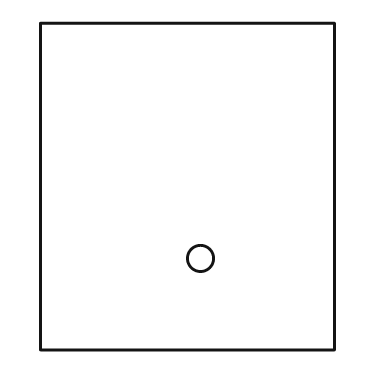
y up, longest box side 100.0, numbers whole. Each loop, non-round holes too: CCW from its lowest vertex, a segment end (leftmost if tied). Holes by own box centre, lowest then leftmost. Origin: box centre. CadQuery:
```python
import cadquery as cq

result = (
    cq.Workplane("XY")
    .moveTo(-45.0, -50.0)
    .lineTo(45.0, -50.0)
    .lineTo(45.0, 50.0)
    .lineTo(-45.0, 50.0)
    .close()
    .moveTo(4.0, -22.0)
    .circle(4.0)
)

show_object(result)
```